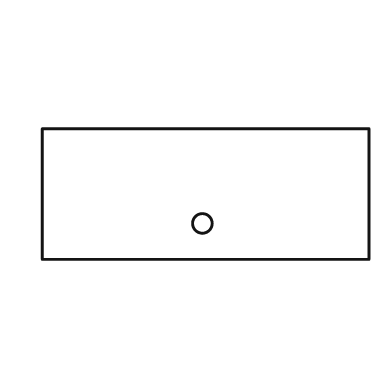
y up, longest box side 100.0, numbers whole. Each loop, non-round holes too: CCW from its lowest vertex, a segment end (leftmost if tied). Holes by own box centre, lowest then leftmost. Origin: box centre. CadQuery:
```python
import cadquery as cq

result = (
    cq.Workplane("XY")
    .moveTo(-50.0, -20.0)
    .lineTo(50.0, -20.0)
    .lineTo(50.0, 20.0)
    .lineTo(-50.0, 20.0)
    .close()
    .moveTo(-1.0, -9.0)
    .circle(3.0)
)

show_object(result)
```